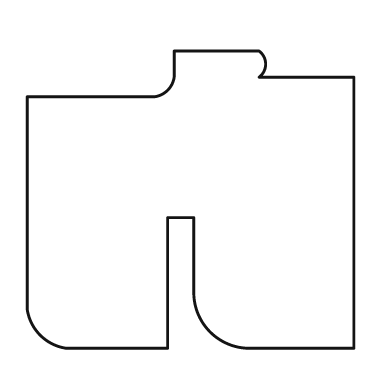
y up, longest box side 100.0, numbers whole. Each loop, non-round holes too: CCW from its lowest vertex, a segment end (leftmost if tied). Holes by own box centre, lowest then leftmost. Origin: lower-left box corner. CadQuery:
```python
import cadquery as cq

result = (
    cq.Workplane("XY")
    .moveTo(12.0, 0.0)
    .lineTo(43.0, 0.0)
    .lineTo(43.0, 40.0)
    .lineTo(51.0, 40.0)
    .lineTo(51.0, 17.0)
    .threePointArc((56.0, 5.0), (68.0, 0.0))
    .lineTo(100.0, 0.0)
    .lineTo(100.0, 83.0)
    .lineTo(71.0, 83.0)
    .threePointArc((73.0, 87.0), (71.0, 91.0))
    .lineTo(45.0, 91.0)
    .lineTo(45.0, 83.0)
    .threePointArc((43.0, 79.0), (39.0, 77.0))
    .lineTo(0.0, 77.0)
    .lineTo(0.0, 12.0)
    .threePointArc((4.0, 4.0), (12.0, 0.0))
    .close()
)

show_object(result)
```